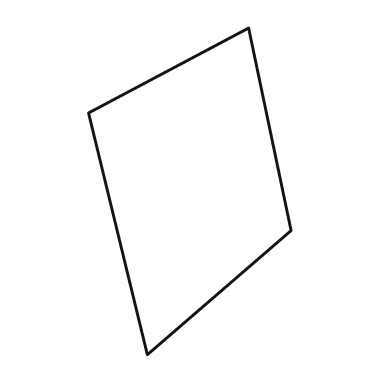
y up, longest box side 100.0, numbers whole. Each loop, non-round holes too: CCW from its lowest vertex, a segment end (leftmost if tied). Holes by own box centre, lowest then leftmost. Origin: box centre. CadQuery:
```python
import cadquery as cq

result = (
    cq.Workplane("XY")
    .moveTo(-13.0, -50.0)
    .lineTo(31.0, -12.0)
    .lineTo(18.0, 50.0)
    .lineTo(-31.0, 24.0)
    .close()
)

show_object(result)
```